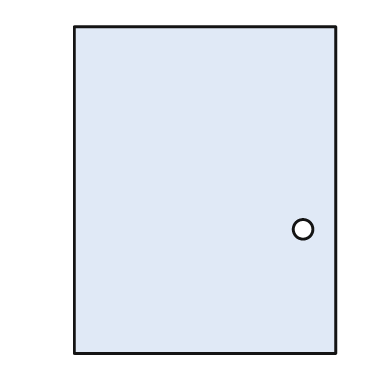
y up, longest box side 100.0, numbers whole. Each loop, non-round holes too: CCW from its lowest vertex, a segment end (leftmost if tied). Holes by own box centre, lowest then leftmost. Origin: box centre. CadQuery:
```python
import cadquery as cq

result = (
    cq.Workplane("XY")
    .moveTo(-40.0, -50.0)
    .lineTo(40.0, -50.0)
    .lineTo(40.0, 50.0)
    .lineTo(-40.0, 50.0)
    .close()
    .moveTo(30.0, -12.0)
    .circle(3.0)
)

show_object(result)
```